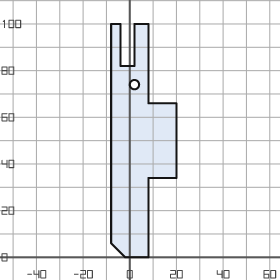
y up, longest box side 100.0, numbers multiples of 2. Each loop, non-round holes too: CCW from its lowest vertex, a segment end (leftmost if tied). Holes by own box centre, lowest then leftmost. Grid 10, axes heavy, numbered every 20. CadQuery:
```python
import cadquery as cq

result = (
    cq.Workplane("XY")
    .moveTo(-2.0, 0.0)
    .lineTo(8.0, 0.0)
    .lineTo(8.0, 34.0)
    .lineTo(20.0, 34.0)
    .lineTo(20.0, 66.0)
    .lineTo(8.0, 66.0)
    .lineTo(8.0, 100.0)
    .lineTo(2.0, 100.0)
    .lineTo(2.0, 82.0)
    .lineTo(-4.0, 82.0)
    .lineTo(-4.0, 100.0)
    .lineTo(-8.0, 100.0)
    .lineTo(-8.0, 6.0)
    .close()
    .moveTo(2.0, 74.0)
    .circle(2.0)
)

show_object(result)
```